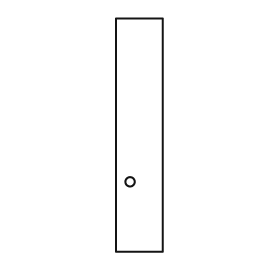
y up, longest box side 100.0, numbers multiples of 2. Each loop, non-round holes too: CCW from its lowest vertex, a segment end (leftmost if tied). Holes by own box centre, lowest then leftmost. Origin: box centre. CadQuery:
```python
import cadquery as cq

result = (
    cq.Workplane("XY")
    .moveTo(-10.0, -50.0)
    .lineTo(10.0, -50.0)
    .lineTo(10.0, 50.0)
    .lineTo(-10.0, 50.0)
    .close()
    .moveTo(-4.0, -20.0)
    .circle(2.0)
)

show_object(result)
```